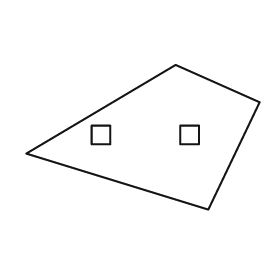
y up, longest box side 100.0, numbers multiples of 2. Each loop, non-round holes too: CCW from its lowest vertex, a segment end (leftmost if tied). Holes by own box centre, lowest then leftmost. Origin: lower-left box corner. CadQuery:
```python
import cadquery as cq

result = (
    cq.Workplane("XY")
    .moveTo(78.0, 0.0)
    .lineTo(100.0, 46.0)
    .lineTo(64.0, 62.0)
    .lineTo(0.0, 24.0)
    .close()
    .moveTo(28.0, 28.0)
    .lineTo(36.0, 28.0)
    .lineTo(36.0, 36.0)
    .lineTo(28.0, 36.0)
    .close()
    .moveTo(66.0, 28.0)
    .lineTo(74.0, 28.0)
    .lineTo(74.0, 36.0)
    .lineTo(66.0, 36.0)
    .close()
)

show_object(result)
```